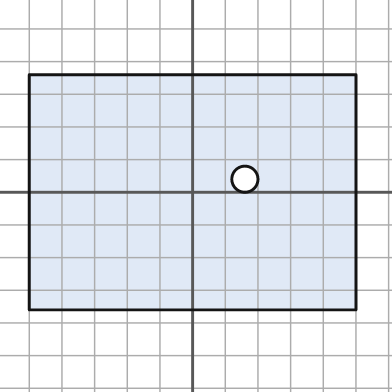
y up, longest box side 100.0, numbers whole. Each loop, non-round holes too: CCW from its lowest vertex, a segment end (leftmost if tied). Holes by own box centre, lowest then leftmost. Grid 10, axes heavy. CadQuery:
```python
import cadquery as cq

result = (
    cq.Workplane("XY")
    .moveTo(-50.0, -36.0)
    .lineTo(50.0, -36.0)
    .lineTo(50.0, 36.0)
    .lineTo(-50.0, 36.0)
    .close()
    .moveTo(16.0, 4.0)
    .circle(4.0)
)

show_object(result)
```